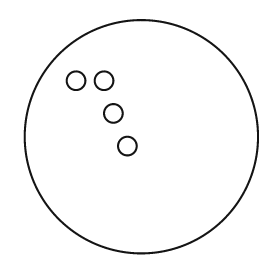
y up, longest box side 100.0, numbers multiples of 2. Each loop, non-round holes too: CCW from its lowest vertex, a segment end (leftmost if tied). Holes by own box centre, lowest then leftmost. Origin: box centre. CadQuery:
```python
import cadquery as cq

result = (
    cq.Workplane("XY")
    .moveTo(0.0, 0.0)
    .circle(50.0)
    .moveTo(-6.0, -4.0)
    .circle(4.0)
    .moveTo(-12.0, 10.0)
    .circle(4.0)
    .moveTo(-28.0, 24.0)
    .circle(4.0)
    .moveTo(-16.0, 24.0)
    .circle(4.0)
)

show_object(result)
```